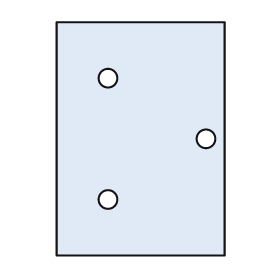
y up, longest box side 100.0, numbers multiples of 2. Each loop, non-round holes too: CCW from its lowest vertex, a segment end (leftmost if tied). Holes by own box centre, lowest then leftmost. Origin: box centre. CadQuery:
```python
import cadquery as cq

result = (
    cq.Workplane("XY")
    .moveTo(-36.0, -50.0)
    .lineTo(36.0, -50.0)
    .lineTo(36.0, 50.0)
    .lineTo(-36.0, 50.0)
    .close()
    .moveTo(-14.0, -26.0)
    .circle(4.0)
    .moveTo(28.0, 0.0)
    .circle(4.0)
    .moveTo(-14.0, 26.0)
    .circle(4.0)
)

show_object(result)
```